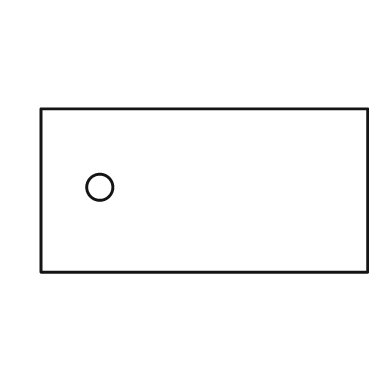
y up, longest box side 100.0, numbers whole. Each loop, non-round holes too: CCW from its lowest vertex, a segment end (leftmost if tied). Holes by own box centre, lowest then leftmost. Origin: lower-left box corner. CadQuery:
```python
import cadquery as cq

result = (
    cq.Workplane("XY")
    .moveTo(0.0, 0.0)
    .lineTo(100.0, 0.0)
    .lineTo(100.0, 50.0)
    .lineTo(0.0, 50.0)
    .close()
    .moveTo(18.0, 26.0)
    .circle(4.0)
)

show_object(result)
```